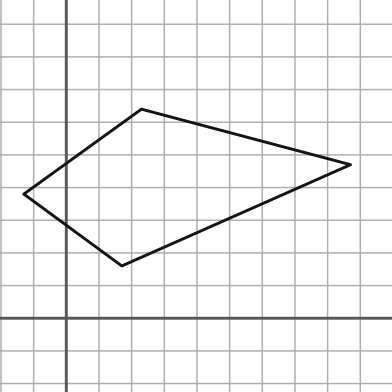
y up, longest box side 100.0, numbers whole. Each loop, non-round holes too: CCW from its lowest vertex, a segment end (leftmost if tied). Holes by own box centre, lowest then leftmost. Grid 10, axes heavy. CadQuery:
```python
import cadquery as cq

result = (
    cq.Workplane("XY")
    .moveTo(17.0, 16.0)
    .lineTo(87.0, 47.0)
    .lineTo(23.0, 64.0)
    .lineTo(-13.0, 38.0)
    .close()
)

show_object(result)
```